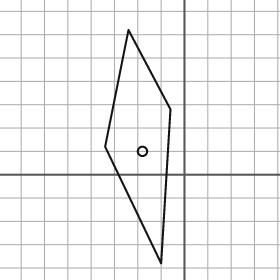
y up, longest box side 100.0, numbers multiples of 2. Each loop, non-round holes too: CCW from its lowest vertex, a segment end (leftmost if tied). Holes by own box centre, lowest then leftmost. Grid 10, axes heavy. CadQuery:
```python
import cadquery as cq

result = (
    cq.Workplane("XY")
    .moveTo(-10.0, -38.0)
    .lineTo(-6.0, 28.0)
    .lineTo(-24.0, 62.0)
    .lineTo(-34.0, 12.0)
    .close()
    .moveTo(-18.0, 10.0)
    .circle(2.0)
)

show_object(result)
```